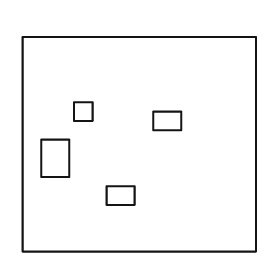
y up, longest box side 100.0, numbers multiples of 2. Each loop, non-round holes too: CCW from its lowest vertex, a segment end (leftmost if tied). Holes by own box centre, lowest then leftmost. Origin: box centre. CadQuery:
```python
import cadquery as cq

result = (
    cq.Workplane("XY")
    .moveTo(-50.0, -46.0)
    .lineTo(50.0, -46.0)
    .lineTo(50.0, 46.0)
    .lineTo(-50.0, 46.0)
    .close()
    .moveTo(-14.0, -26.0)
    .lineTo(-2.0, -26.0)
    .lineTo(-2.0, -18.0)
    .lineTo(-14.0, -18.0)
    .close()
    .moveTo(-42.0, -14.0)
    .lineTo(-30.0, -14.0)
    .lineTo(-30.0, 2.0)
    .lineTo(-42.0, 2.0)
    .close()
    .moveTo(6.0, 6.0)
    .lineTo(18.0, 6.0)
    .lineTo(18.0, 14.0)
    .lineTo(6.0, 14.0)
    .close()
    .moveTo(-28.0, 10.0)
    .lineTo(-20.0, 10.0)
    .lineTo(-20.0, 18.0)
    .lineTo(-28.0, 18.0)
    .close()
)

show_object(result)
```